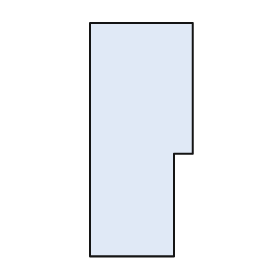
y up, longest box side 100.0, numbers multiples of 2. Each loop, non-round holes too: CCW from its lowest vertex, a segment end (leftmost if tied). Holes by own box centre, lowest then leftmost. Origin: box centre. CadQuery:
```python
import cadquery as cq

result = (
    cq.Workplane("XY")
    .moveTo(-22.0, -50.0)
    .lineTo(14.0, -50.0)
    .lineTo(14.0, -6.0)
    .lineTo(22.0, -6.0)
    .lineTo(22.0, 50.0)
    .lineTo(-22.0, 50.0)
    .close()
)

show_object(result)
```